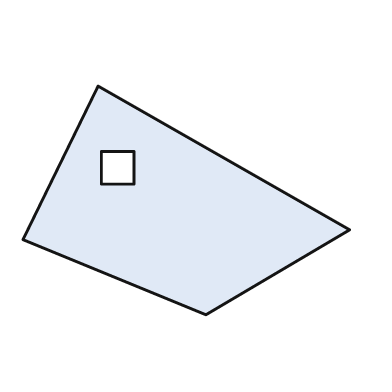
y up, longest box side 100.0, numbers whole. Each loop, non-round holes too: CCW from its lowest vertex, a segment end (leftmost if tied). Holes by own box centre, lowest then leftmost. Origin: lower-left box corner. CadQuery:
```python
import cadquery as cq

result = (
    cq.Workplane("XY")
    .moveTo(56.0, 0.0)
    .lineTo(100.0, 26.0)
    .lineTo(23.0, 70.0)
    .lineTo(0.0, 23.0)
    .close()
    .moveTo(24.0, 40.0)
    .lineTo(34.0, 40.0)
    .lineTo(34.0, 50.0)
    .lineTo(24.0, 50.0)
    .close()
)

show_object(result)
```